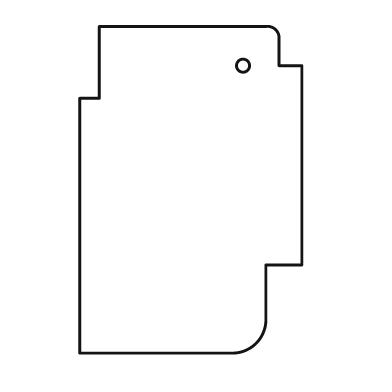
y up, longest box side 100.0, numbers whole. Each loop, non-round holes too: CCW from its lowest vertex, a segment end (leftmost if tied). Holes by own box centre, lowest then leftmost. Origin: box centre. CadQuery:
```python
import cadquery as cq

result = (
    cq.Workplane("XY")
    .moveTo(-34.0, -50.0)
    .lineTo(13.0, -50.0)
    .threePointArc((20.0, -47.0), (23.0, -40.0))
    .lineTo(23.0, -23.0)
    .lineTo(34.0, -23.0)
    .lineTo(34.0, 38.0)
    .lineTo(27.0, 38.0)
    .lineTo(27.0, 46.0)
    .threePointArc((26.0, 49.0), (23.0, 50.0))
    .lineTo(-28.0, 50.0)
    .lineTo(-28.0, 28.0)
    .lineTo(-34.0, 28.0)
    .close()
    .moveTo(16.0, 38.0)
    .circle(2.0)
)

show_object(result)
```